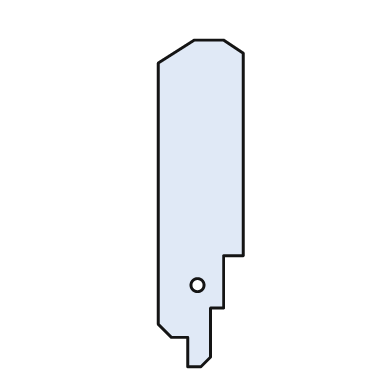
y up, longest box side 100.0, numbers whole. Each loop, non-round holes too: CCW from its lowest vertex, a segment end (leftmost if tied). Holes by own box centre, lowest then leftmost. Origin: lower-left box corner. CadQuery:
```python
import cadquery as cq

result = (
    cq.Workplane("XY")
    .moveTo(9.0, 0.0)
    .lineTo(13.0, 0.0)
    .lineTo(16.0, 3.0)
    .lineTo(16.0, 18.0)
    .lineTo(20.0, 18.0)
    .lineTo(20.0, 34.0)
    .lineTo(26.0, 34.0)
    .lineTo(26.0, 96.0)
    .lineTo(20.0, 100.0)
    .lineTo(11.0, 100.0)
    .lineTo(0.0, 93.0)
    .lineTo(0.0, 13.0)
    .lineTo(4.0, 9.0)
    .lineTo(9.0, 9.0)
    .close()
    .moveTo(12.0, 25.0)
    .circle(2.0)
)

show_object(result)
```